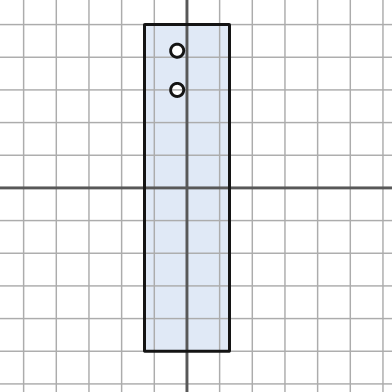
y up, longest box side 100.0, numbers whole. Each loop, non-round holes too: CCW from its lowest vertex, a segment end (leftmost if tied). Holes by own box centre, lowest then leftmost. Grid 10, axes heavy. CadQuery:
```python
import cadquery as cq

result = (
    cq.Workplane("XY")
    .moveTo(-13.0, -50.0)
    .lineTo(13.0, -50.0)
    .lineTo(13.0, 50.0)
    .lineTo(-13.0, 50.0)
    .close()
    .moveTo(-3.0, 30.0)
    .circle(2.0)
    .moveTo(-3.0, 42.0)
    .circle(2.0)
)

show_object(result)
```